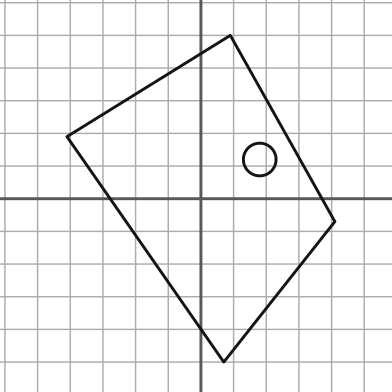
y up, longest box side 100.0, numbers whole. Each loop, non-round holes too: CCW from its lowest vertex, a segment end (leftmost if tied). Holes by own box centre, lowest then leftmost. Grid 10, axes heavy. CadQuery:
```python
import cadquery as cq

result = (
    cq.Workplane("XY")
    .moveTo(7.0, -50.0)
    .lineTo(41.0, -7.0)
    .lineTo(9.0, 50.0)
    .lineTo(-41.0, 19.0)
    .close()
    .moveTo(18.0, 12.0)
    .circle(5.0)
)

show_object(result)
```